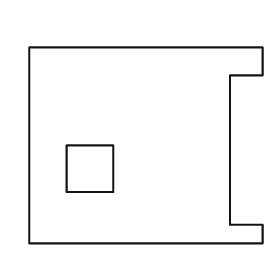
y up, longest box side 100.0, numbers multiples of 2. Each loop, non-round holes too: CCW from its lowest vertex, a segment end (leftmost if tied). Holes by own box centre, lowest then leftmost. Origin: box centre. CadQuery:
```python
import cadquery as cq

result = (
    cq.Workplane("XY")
    .moveTo(-50.0, -42.0)
    .lineTo(50.0, -42.0)
    .lineTo(50.0, -34.0)
    .lineTo(36.0, -34.0)
    .lineTo(36.0, 30.0)
    .lineTo(50.0, 30.0)
    .lineTo(50.0, 42.0)
    .lineTo(-50.0, 42.0)
    .close()
    .moveTo(-34.0, -20.0)
    .lineTo(-14.0, -20.0)
    .lineTo(-14.0, 0.0)
    .lineTo(-34.0, 0.0)
    .close()
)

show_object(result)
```